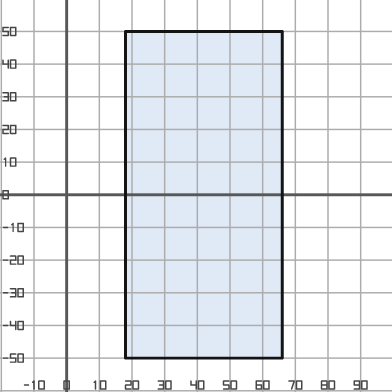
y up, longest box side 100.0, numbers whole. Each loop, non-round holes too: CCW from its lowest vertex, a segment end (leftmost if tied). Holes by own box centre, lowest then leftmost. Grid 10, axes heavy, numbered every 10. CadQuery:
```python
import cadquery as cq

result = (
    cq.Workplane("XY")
    .moveTo(18.0, -50.0)
    .lineTo(66.0, -50.0)
    .lineTo(66.0, 50.0)
    .lineTo(18.0, 50.0)
    .close()
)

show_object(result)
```